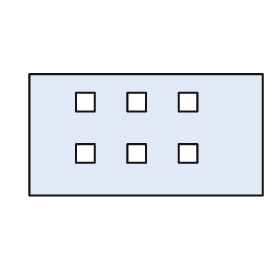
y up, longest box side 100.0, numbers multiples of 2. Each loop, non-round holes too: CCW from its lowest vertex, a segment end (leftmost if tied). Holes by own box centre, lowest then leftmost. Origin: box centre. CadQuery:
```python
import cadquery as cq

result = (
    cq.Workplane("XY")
    .moveTo(-50.0, -26.0)
    .lineTo(50.0, -26.0)
    .lineTo(50.0, 26.0)
    .lineTo(-50.0, 26.0)
    .close()
    .moveTo(-30.0, -12.0)
    .lineTo(-22.0, -12.0)
    .lineTo(-22.0, -4.0)
    .lineTo(-30.0, -4.0)
    .close()
    .moveTo(-8.0, -12.0)
    .lineTo(0.0, -12.0)
    .lineTo(0.0, -4.0)
    .lineTo(-8.0, -4.0)
    .close()
    .moveTo(14.0, -12.0)
    .lineTo(22.0, -12.0)
    .lineTo(22.0, -4.0)
    .lineTo(14.0, -4.0)
    .close()
    .moveTo(-30.0, 10.0)
    .lineTo(-22.0, 10.0)
    .lineTo(-22.0, 18.0)
    .lineTo(-30.0, 18.0)
    .close()
    .moveTo(-8.0, 10.0)
    .lineTo(0.0, 10.0)
    .lineTo(0.0, 18.0)
    .lineTo(-8.0, 18.0)
    .close()
    .moveTo(14.0, 10.0)
    .lineTo(22.0, 10.0)
    .lineTo(22.0, 18.0)
    .lineTo(14.0, 18.0)
    .close()
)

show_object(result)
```